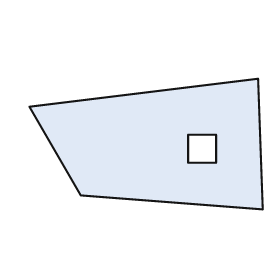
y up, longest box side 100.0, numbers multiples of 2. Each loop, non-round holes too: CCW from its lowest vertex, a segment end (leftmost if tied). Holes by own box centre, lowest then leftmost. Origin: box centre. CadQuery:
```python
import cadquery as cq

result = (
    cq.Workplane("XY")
    .moveTo(50.0, -28.0)
    .lineTo(48.0, 28.0)
    .lineTo(-50.0, 16.0)
    .lineTo(-28.0, -22.0)
    .close()
    .moveTo(18.0, -8.0)
    .lineTo(30.0, -8.0)
    .lineTo(30.0, 4.0)
    .lineTo(18.0, 4.0)
    .close()
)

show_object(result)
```